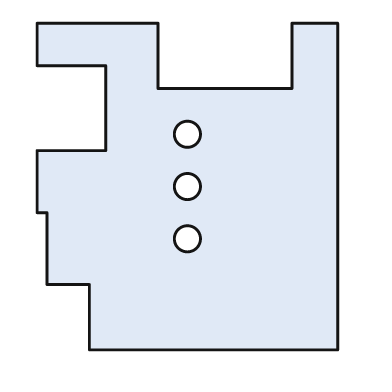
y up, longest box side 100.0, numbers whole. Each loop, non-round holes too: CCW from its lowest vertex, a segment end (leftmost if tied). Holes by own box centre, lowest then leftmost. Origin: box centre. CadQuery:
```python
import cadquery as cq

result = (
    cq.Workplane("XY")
    .moveTo(-30.0, -50.0)
    .lineTo(46.0, -50.0)
    .lineTo(46.0, 50.0)
    .lineTo(32.0, 50.0)
    .lineTo(32.0, 30.0)
    .lineTo(-9.0, 30.0)
    .lineTo(-9.0, 50.0)
    .lineTo(-46.0, 50.0)
    .lineTo(-46.0, 37.0)
    .lineTo(-25.0, 37.0)
    .lineTo(-25.0, 11.0)
    .lineTo(-46.0, 11.0)
    .lineTo(-46.0, -8.0)
    .lineTo(-43.0, -8.0)
    .lineTo(-43.0, -30.0)
    .lineTo(-30.0, -30.0)
    .close()
    .moveTo(0.0, -16.0)
    .circle(4.0)
    .moveTo(0.0, 0.0)
    .circle(4.0)
    .moveTo(0.0, 16.0)
    .circle(4.0)
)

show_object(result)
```